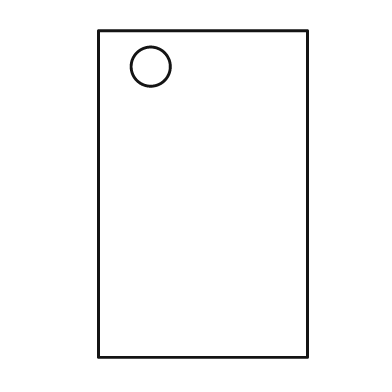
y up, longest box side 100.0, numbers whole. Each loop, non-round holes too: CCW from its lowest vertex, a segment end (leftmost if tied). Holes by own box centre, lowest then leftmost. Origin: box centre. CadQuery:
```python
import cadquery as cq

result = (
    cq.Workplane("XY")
    .moveTo(-32.0, -50.0)
    .lineTo(32.0, -50.0)
    .lineTo(32.0, 50.0)
    .lineTo(-32.0, 50.0)
    .close()
    .moveTo(-16.0, 39.0)
    .circle(6.0)
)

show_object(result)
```